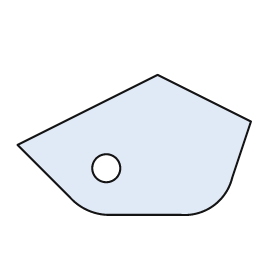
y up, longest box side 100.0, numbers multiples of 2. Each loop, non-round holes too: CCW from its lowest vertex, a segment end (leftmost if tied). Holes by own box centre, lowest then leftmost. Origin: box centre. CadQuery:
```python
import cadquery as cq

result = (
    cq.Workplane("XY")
    .moveTo(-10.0, -30.0)
    .lineTo(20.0, -30.0)
    .threePointArc((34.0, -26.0), (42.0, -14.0))
    .lineTo(50.0, 10.0)
    .lineTo(10.0, 30.0)
    .lineTo(-50.0, 0.0)
    .lineTo(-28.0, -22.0)
    .threePointArc((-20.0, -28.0), (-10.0, -30.0))
    .close()
    .moveTo(-12.0, -10.0)
    .circle(6.0)
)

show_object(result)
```